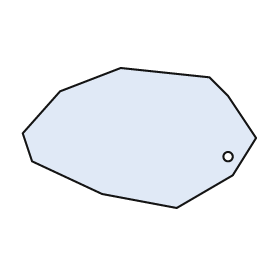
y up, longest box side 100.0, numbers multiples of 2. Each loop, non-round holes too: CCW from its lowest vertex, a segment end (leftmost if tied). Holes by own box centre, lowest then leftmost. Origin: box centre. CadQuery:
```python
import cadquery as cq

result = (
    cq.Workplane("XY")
    .moveTo(16.0, -30.0)
    .lineTo(40.0, -16.0)
    .lineTo(50.0, 0.0)
    .lineTo(38.0, 18.0)
    .lineTo(30.0, 26.0)
    .lineTo(-8.0, 30.0)
    .lineTo(-34.0, 20.0)
    .lineTo(-50.0, 2.0)
    .lineTo(-46.0, -10.0)
    .lineTo(-16.0, -24.0)
    .close()
    .moveTo(38.0, -8.0)
    .circle(2.0)
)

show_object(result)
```